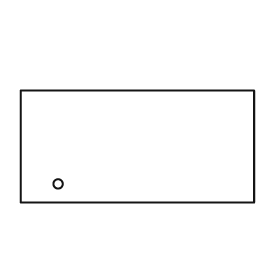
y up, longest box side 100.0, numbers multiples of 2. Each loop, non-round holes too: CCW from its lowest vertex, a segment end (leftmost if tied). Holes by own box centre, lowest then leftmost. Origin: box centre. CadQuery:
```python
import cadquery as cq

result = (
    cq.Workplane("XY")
    .moveTo(-50.0, -24.0)
    .lineTo(50.0, -24.0)
    .lineTo(50.0, 24.0)
    .lineTo(-50.0, 24.0)
    .close()
    .moveTo(-34.0, -16.0)
    .circle(2.0)
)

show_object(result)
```